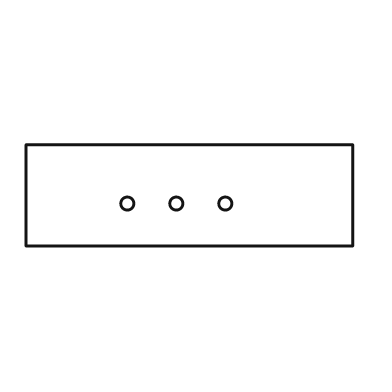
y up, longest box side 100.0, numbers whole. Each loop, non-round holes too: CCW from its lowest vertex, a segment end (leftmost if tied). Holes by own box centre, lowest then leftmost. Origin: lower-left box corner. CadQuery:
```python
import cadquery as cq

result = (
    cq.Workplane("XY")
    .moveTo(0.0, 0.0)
    .lineTo(100.0, 0.0)
    .lineTo(100.0, 31.0)
    .lineTo(0.0, 31.0)
    .close()
    .moveTo(31.0, 13.0)
    .circle(2.0)
    .moveTo(46.0, 13.0)
    .circle(2.0)
    .moveTo(61.0, 13.0)
    .circle(2.0)
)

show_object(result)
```